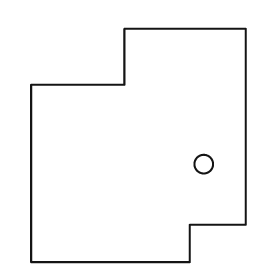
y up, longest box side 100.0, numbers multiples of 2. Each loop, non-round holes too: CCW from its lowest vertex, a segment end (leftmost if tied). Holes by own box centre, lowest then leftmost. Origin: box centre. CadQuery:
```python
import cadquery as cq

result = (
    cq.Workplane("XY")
    .moveTo(-46.0, -50.0)
    .lineTo(22.0, -50.0)
    .lineTo(22.0, -34.0)
    .lineTo(46.0, -34.0)
    .lineTo(46.0, 50.0)
    .lineTo(-6.0, 50.0)
    .lineTo(-6.0, 26.0)
    .lineTo(-46.0, 26.0)
    .close()
    .moveTo(28.0, -8.0)
    .circle(4.0)
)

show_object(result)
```